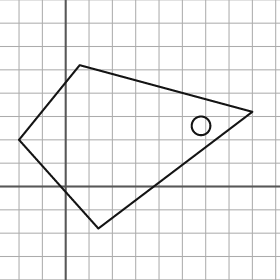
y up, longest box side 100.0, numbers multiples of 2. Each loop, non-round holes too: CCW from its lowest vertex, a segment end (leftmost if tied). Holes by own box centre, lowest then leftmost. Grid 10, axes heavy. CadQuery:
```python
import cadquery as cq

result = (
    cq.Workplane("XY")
    .moveTo(14.0, -18.0)
    .lineTo(80.0, 32.0)
    .lineTo(6.0, 52.0)
    .lineTo(-20.0, 20.0)
    .close()
    .moveTo(58.0, 26.0)
    .circle(4.0)
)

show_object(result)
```